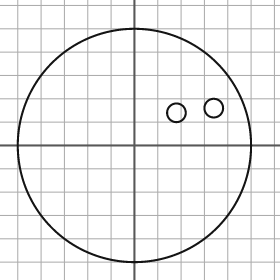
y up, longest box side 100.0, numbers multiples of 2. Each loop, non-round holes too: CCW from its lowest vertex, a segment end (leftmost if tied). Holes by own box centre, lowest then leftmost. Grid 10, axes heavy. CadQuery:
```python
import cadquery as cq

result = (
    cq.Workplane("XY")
    .moveTo(0.0, 0.0)
    .circle(50.0)
    .moveTo(18.0, 14.0)
    .circle(4.0)
    .moveTo(34.0, 16.0)
    .circle(4.0)
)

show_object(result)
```